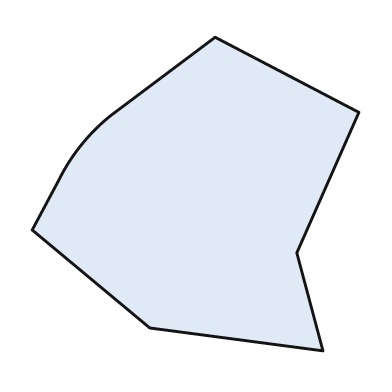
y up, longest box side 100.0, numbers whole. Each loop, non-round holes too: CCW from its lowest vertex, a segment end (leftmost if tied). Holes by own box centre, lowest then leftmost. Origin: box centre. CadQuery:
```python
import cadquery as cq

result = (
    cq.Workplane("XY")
    .moveTo(39.0, -48.0)
    .lineTo(31.0, -18.0)
    .lineTo(50.0, 25.0)
    .lineTo(6.0, 48.0)
    .lineTo(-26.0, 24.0)
    .threePointArc((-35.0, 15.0), (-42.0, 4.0))
    .lineTo(-50.0, -11.0)
    .lineTo(-14.0, -41.0)
    .close()
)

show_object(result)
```